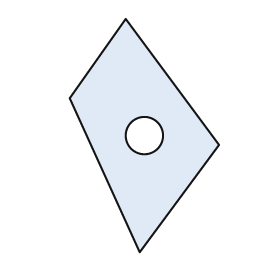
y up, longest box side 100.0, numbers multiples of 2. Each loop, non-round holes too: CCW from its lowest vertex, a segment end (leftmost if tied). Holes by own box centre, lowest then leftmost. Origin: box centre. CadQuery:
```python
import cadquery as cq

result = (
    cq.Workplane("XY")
    .moveTo(-2.0, -50.0)
    .lineTo(32.0, -4.0)
    .lineTo(-8.0, 50.0)
    .lineTo(-32.0, 16.0)
    .close()
    .moveTo(0.0, 0.0)
    .circle(8.0)
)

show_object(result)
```